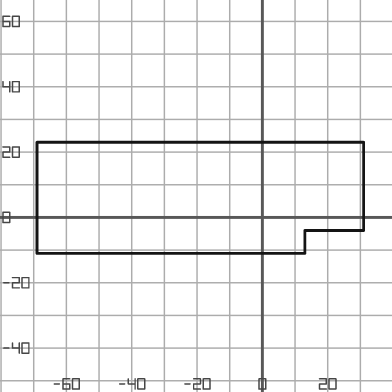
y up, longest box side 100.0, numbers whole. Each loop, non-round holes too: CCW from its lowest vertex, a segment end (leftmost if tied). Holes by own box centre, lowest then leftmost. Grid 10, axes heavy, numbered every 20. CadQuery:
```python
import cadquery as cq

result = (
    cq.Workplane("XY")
    .moveTo(-69.0, -11.0)
    .lineTo(13.0, -11.0)
    .lineTo(13.0, -4.0)
    .lineTo(31.0, -4.0)
    .lineTo(31.0, 23.0)
    .lineTo(-69.0, 23.0)
    .close()
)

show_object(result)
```